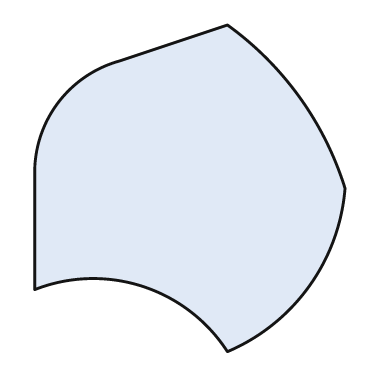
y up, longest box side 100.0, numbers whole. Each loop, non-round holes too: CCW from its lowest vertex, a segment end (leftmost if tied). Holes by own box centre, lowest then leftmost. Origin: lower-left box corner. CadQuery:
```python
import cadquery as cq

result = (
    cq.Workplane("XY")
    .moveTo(59.0, 0.0)
    .threePointArc((84.0, 20.0), (95.0, 50.0))
    .threePointArc((81.0, 78.0), (59.0, 100.0))
    .lineTo(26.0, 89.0)
    .threePointArc((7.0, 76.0), (0.0, 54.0))
    .lineTo(0.0, 19.0)
    .threePointArc((33.0, 20.0), (59.0, 0.0))
    .close()
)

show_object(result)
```